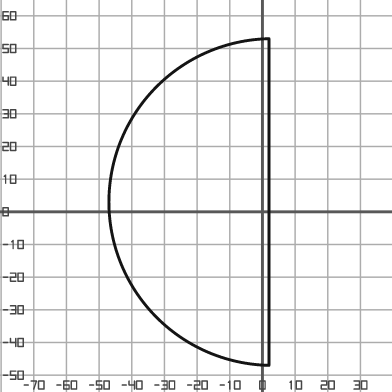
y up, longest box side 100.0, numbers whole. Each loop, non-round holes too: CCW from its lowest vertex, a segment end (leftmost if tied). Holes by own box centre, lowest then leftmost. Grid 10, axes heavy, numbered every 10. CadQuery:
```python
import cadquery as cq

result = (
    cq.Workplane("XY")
    .moveTo(2.0, -47.0)
    .lineTo(2.0, 53.0)
    .threePointArc((-47.0, 3.0), (2.0, -47.0))
    .close()
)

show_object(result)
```